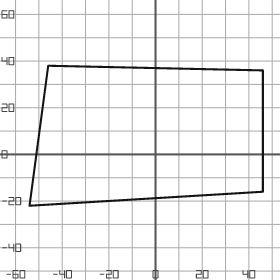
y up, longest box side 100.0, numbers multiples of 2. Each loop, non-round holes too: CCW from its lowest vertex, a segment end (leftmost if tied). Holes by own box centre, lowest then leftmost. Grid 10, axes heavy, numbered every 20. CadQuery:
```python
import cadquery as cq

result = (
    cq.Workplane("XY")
    .moveTo(-54.0, -22.0)
    .lineTo(46.0, -16.0)
    .lineTo(46.0, 36.0)
    .lineTo(-46.0, 38.0)
    .close()
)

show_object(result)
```